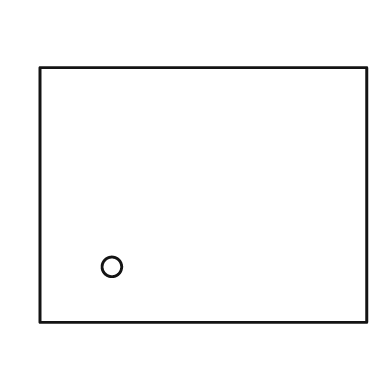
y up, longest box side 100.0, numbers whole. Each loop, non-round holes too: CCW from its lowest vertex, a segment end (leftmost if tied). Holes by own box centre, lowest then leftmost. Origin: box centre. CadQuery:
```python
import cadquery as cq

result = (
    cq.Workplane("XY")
    .moveTo(-50.0, -39.0)
    .lineTo(50.0, -39.0)
    .lineTo(50.0, 39.0)
    .lineTo(-50.0, 39.0)
    .close()
    .moveTo(-28.0, -22.0)
    .circle(3.0)
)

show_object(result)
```